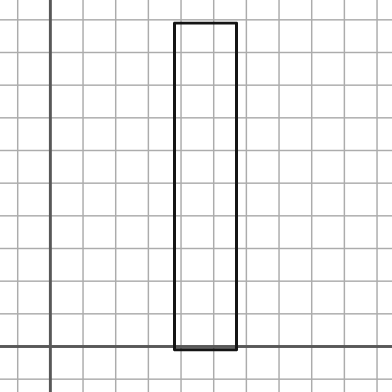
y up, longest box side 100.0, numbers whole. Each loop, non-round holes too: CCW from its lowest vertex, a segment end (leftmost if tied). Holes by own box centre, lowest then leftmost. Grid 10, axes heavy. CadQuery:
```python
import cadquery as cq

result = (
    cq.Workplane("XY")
    .moveTo(38.0, -1.0)
    .lineTo(57.0, -1.0)
    .lineTo(57.0, 99.0)
    .lineTo(38.0, 99.0)
    .close()
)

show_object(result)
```